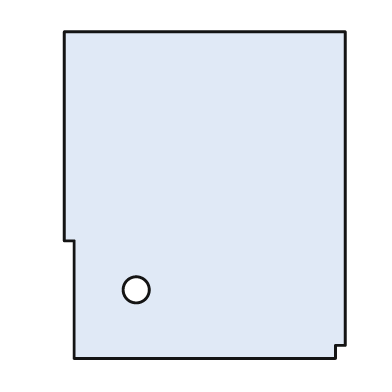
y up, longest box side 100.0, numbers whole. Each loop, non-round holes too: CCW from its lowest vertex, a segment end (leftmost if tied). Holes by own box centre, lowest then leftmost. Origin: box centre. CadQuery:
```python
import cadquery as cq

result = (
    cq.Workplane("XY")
    .moveTo(-40.0, -50.0)
    .lineTo(40.0, -50.0)
    .lineTo(40.0, -46.0)
    .lineTo(43.0, -46.0)
    .lineTo(43.0, 50.0)
    .lineTo(-43.0, 50.0)
    .lineTo(-43.0, -14.0)
    .lineTo(-40.0, -14.0)
    .close()
    .moveTo(-21.0, -29.0)
    .circle(4.0)
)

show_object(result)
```